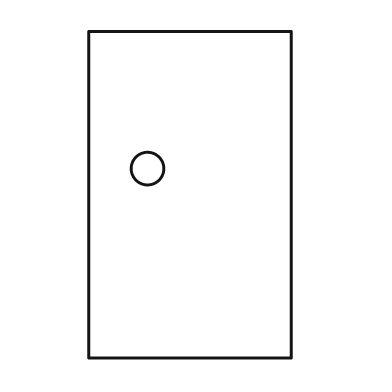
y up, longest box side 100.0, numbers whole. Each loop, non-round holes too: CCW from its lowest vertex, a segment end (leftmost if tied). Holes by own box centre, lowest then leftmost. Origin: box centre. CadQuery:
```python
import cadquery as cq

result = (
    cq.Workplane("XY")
    .moveTo(-31.0, -50.0)
    .lineTo(31.0, -50.0)
    .lineTo(31.0, 50.0)
    .lineTo(-31.0, 50.0)
    .close()
    .moveTo(-13.0, 8.0)
    .circle(5.0)
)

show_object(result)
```